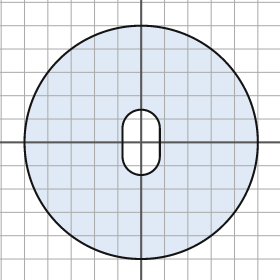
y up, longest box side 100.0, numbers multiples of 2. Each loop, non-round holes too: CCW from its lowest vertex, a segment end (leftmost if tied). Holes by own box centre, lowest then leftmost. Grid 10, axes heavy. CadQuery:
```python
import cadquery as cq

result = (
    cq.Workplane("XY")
    .moveTo(0.0, 0.0)
    .circle(50.0)
    .moveTo(-8.0, -6.0)
    .threePointArc((0.0, -14.0), (8.0, -6.0))
    .lineTo(8.0, 6.0)
    .threePointArc((0.0, 14.0), (-8.0, 6.0))
    .close()
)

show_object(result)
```